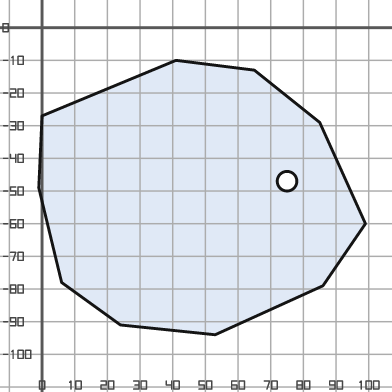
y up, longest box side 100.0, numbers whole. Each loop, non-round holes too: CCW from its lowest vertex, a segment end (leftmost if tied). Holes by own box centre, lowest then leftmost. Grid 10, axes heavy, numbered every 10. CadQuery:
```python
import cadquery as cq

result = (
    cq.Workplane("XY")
    .moveTo(53.0, -94.0)
    .lineTo(86.0, -79.0)
    .lineTo(99.0, -60.0)
    .lineTo(85.0, -29.0)
    .lineTo(65.0, -13.0)
    .lineTo(41.0, -10.0)
    .lineTo(0.0, -27.0)
    .lineTo(-1.0, -49.0)
    .lineTo(6.0, -78.0)
    .lineTo(24.0, -91.0)
    .close()
    .moveTo(75.0, -47.0)
    .circle(3.0)
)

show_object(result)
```